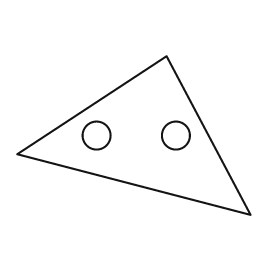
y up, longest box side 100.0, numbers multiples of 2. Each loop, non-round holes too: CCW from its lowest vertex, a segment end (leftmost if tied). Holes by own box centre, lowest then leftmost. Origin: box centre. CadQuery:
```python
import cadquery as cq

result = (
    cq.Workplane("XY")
    .moveTo(50.0, -34.0)
    .lineTo(14.0, 34.0)
    .lineTo(-50.0, -8.0)
    .close()
    .moveTo(-16.0, 0.0)
    .circle(6.0)
    .moveTo(18.0, 0.0)
    .circle(6.0)
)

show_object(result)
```